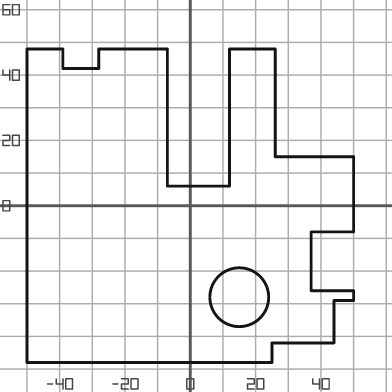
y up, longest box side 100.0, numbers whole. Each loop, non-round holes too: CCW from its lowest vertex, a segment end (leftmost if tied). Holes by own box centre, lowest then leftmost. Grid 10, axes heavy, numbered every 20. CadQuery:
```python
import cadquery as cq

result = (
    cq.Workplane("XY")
    .moveTo(-50.0, -48.0)
    .lineTo(25.0, -48.0)
    .lineTo(25.0, -42.0)
    .lineTo(44.0, -42.0)
    .lineTo(44.0, -29.0)
    .lineTo(50.0, -29.0)
    .lineTo(50.0, -26.0)
    .lineTo(37.0, -26.0)
    .lineTo(37.0, -8.0)
    .lineTo(50.0, -8.0)
    .lineTo(50.0, 15.0)
    .lineTo(26.0, 15.0)
    .lineTo(26.0, 48.0)
    .lineTo(12.0, 48.0)
    .lineTo(12.0, 6.0)
    .lineTo(-7.0, 6.0)
    .lineTo(-7.0, 48.0)
    .lineTo(-28.0, 48.0)
    .lineTo(-28.0, 42.0)
    .lineTo(-39.0, 42.0)
    .lineTo(-39.0, 48.0)
    .lineTo(-50.0, 48.0)
    .close()
    .moveTo(15.0, -28.0)
    .circle(9.0)
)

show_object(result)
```